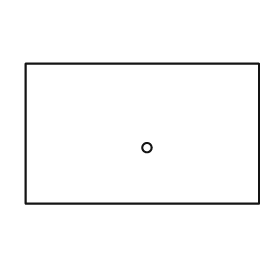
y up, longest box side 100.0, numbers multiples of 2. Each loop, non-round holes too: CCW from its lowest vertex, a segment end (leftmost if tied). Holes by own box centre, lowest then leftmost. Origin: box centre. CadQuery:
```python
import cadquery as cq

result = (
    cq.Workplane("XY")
    .moveTo(-50.0, -30.0)
    .lineTo(50.0, -30.0)
    .lineTo(50.0, 30.0)
    .lineTo(-50.0, 30.0)
    .close()
    .moveTo(2.0, -6.0)
    .circle(2.0)
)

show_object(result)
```